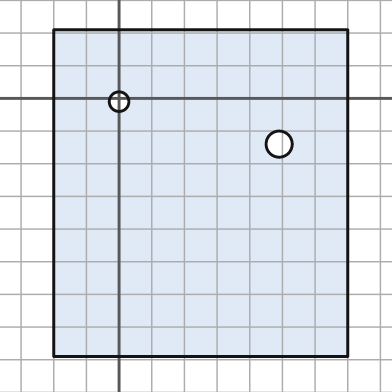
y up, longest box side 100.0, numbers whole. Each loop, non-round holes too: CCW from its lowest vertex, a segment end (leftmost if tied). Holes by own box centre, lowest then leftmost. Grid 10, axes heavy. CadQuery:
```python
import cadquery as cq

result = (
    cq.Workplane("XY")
    .moveTo(-20.0, -79.0)
    .lineTo(70.0, -79.0)
    .lineTo(70.0, 21.0)
    .lineTo(-20.0, 21.0)
    .close()
    .moveTo(49.0, -14.0)
    .circle(4.0)
    .moveTo(0.0, -1.0)
    .circle(3.0)
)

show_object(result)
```